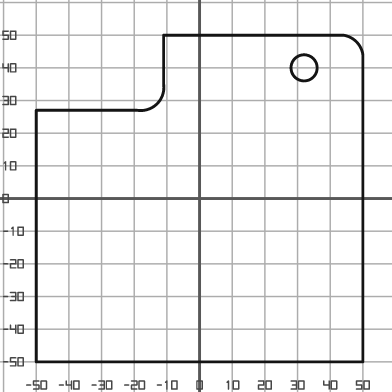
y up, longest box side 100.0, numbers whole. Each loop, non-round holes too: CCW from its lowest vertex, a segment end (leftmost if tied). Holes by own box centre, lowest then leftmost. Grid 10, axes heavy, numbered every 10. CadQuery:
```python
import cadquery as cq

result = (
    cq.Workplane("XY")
    .moveTo(-50.0, -50.0)
    .lineTo(50.0, -50.0)
    .lineTo(50.0, 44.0)
    .threePointArc((48.0, 48.0), (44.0, 50.0))
    .lineTo(-11.0, 50.0)
    .lineTo(-11.0, 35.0)
    .threePointArc((-13.0, 29.0), (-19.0, 27.0))
    .lineTo(-50.0, 27.0)
    .close()
    .moveTo(32.0, 40.0)
    .circle(4.0)
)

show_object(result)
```